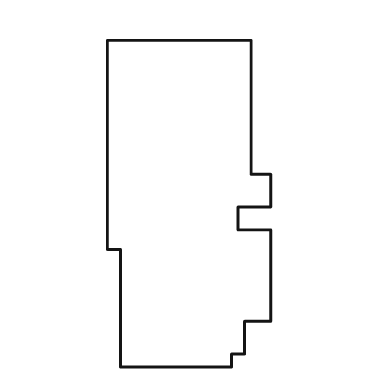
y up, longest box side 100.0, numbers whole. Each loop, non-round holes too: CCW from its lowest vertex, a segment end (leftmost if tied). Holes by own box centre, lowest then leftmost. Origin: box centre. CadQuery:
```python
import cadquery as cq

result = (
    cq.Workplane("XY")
    .moveTo(-21.0, -50.0)
    .lineTo(13.0, -50.0)
    .lineTo(13.0, -46.0)
    .lineTo(17.0, -46.0)
    .lineTo(17.0, -36.0)
    .lineTo(25.0, -36.0)
    .lineTo(25.0, -8.0)
    .lineTo(15.0, -8.0)
    .lineTo(15.0, -1.0)
    .lineTo(25.0, -1.0)
    .lineTo(25.0, 9.0)
    .lineTo(19.0, 9.0)
    .lineTo(19.0, 50.0)
    .lineTo(-25.0, 50.0)
    .lineTo(-25.0, -14.0)
    .lineTo(-21.0, -14.0)
    .close()
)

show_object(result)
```